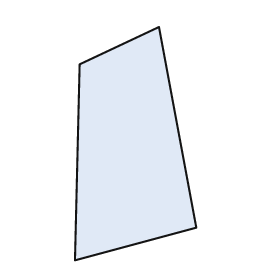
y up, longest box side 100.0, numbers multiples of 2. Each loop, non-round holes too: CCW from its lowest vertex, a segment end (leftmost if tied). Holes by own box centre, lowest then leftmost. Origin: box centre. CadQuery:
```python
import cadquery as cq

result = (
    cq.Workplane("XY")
    .moveTo(-26.0, -50.0)
    .lineTo(26.0, -36.0)
    .lineTo(10.0, 50.0)
    .lineTo(-24.0, 34.0)
    .close()
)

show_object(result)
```